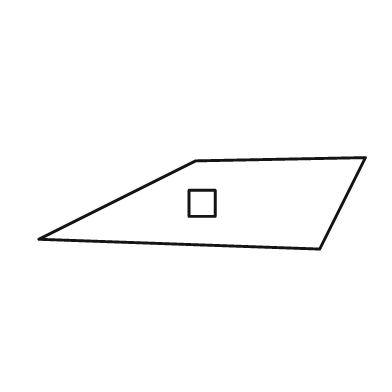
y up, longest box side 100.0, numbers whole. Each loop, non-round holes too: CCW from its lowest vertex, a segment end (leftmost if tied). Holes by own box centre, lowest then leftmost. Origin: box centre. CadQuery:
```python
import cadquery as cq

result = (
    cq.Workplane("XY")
    .moveTo(36.0, -14.0)
    .lineTo(50.0, 14.0)
    .lineTo(-2.0, 13.0)
    .lineTo(-50.0, -11.0)
    .close()
    .moveTo(-4.0, -4.0)
    .lineTo(4.0, -4.0)
    .lineTo(4.0, 4.0)
    .lineTo(-4.0, 4.0)
    .close()
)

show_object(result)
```